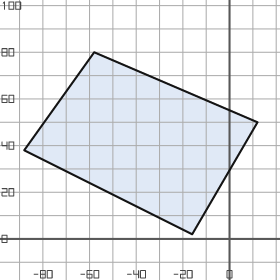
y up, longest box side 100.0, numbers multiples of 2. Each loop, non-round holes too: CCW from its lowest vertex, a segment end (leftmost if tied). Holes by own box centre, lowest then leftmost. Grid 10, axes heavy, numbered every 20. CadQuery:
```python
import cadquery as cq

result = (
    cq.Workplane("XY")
    .moveTo(-16.0, 2.0)
    .lineTo(12.0, 50.0)
    .lineTo(-58.0, 80.0)
    .lineTo(-88.0, 38.0)
    .close()
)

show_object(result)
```